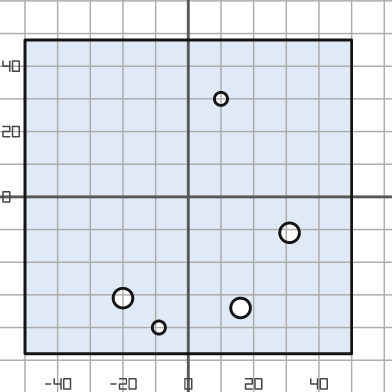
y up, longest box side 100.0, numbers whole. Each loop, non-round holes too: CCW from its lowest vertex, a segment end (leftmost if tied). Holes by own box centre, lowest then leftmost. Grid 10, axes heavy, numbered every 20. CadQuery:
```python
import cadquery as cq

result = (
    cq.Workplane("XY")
    .moveTo(-50.0, -48.0)
    .lineTo(50.0, -48.0)
    .lineTo(50.0, 48.0)
    .lineTo(-50.0, 48.0)
    .close()
    .moveTo(-9.0, -40.0)
    .circle(2.0)
    .moveTo(16.0, -34.0)
    .circle(3.0)
    .moveTo(-20.0, -31.0)
    .circle(3.0)
    .moveTo(31.0, -11.0)
    .circle(3.0)
    .moveTo(10.0, 30.0)
    .circle(2.0)
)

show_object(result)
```